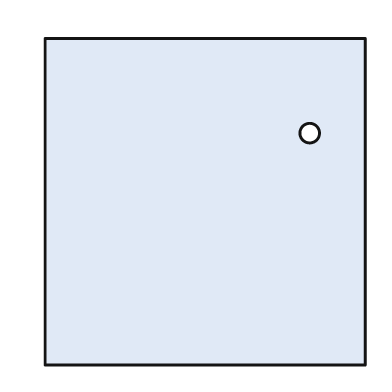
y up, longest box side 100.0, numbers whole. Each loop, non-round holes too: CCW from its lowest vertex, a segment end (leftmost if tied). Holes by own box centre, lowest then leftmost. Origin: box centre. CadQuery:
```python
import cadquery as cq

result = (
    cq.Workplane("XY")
    .moveTo(-49.0, -50.0)
    .lineTo(49.0, -50.0)
    .lineTo(49.0, 50.0)
    .lineTo(-49.0, 50.0)
    .close()
    .moveTo(32.0, 21.0)
    .circle(3.0)
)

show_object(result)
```